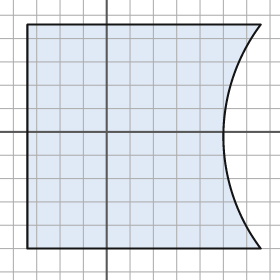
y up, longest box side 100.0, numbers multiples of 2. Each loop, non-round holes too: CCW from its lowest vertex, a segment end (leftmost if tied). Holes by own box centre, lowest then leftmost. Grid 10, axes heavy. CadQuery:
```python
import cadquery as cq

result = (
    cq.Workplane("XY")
    .moveTo(-34.0, -50.0)
    .lineTo(66.0, -50.0)
    .threePointArc((50.0, -2.0), (66.0, 46.0))
    .lineTo(-34.0, 46.0)
    .close()
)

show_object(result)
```